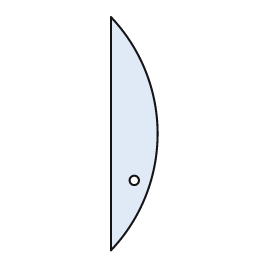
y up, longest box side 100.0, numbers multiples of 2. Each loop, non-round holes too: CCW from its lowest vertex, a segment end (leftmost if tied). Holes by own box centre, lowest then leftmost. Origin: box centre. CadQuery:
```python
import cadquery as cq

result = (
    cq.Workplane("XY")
    .moveTo(-10.0, -50.0)
    .threePointArc((10.0, 0.0), (-10.0, 50.0))
    .close()
    .moveTo(0.0, -20.0)
    .circle(2.0)
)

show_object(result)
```